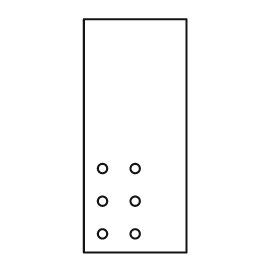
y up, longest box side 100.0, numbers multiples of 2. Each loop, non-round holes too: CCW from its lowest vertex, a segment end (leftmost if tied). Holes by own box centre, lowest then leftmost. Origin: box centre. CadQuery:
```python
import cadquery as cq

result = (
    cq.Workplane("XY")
    .moveTo(-22.0, -50.0)
    .lineTo(22.0, -50.0)
    .lineTo(22.0, 50.0)
    .lineTo(-22.0, 50.0)
    .close()
    .moveTo(-14.0, -42.0)
    .circle(2.0)
    .moveTo(0.0, -42.0)
    .circle(2.0)
    .moveTo(-14.0, -28.0)
    .circle(2.0)
    .moveTo(0.0, -28.0)
    .circle(2.0)
    .moveTo(-14.0, -14.0)
    .circle(2.0)
    .moveTo(0.0, -14.0)
    .circle(2.0)
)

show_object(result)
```